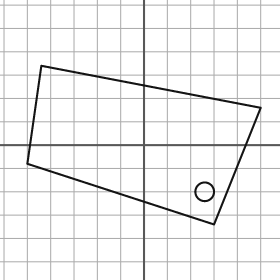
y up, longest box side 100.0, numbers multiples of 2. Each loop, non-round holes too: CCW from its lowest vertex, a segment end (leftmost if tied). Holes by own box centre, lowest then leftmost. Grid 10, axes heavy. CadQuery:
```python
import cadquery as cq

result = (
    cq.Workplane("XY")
    .moveTo(30.0, -34.0)
    .lineTo(50.0, 16.0)
    .lineTo(-44.0, 34.0)
    .lineTo(-50.0, -8.0)
    .close()
    .moveTo(26.0, -20.0)
    .circle(4.0)
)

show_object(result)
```